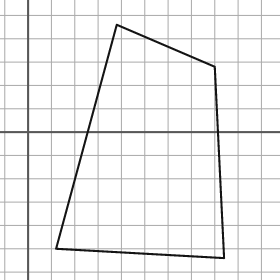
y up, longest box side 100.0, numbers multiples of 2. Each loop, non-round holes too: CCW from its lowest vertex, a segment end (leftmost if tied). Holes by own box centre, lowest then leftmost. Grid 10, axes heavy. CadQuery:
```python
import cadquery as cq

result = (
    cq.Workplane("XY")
    .moveTo(84.0, -54.0)
    .lineTo(80.0, 28.0)
    .lineTo(38.0, 46.0)
    .lineTo(12.0, -50.0)
    .close()
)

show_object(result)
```